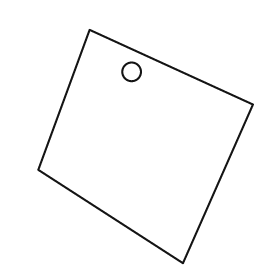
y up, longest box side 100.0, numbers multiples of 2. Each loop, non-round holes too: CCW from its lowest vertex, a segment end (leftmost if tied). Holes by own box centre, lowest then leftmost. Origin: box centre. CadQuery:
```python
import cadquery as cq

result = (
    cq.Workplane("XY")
    .moveTo(16.0, -50.0)
    .lineTo(46.0, 18.0)
    .lineTo(-24.0, 50.0)
    .lineTo(-46.0, -10.0)
    .close()
    .moveTo(-6.0, 32.0)
    .circle(4.0)
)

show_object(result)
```